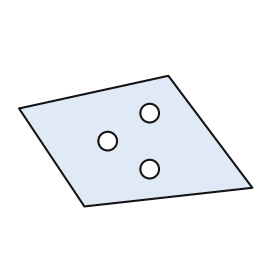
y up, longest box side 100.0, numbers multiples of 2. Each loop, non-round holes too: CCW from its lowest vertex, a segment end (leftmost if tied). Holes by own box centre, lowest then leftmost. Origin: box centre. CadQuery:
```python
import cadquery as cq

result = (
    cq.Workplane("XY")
    .moveTo(-22.0, -28.0)
    .lineTo(50.0, -20.0)
    .lineTo(14.0, 28.0)
    .lineTo(-50.0, 14.0)
    .close()
    .moveTo(6.0, -12.0)
    .circle(4.0)
    .moveTo(-12.0, 0.0)
    .circle(4.0)
    .moveTo(6.0, 12.0)
    .circle(4.0)
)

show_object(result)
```